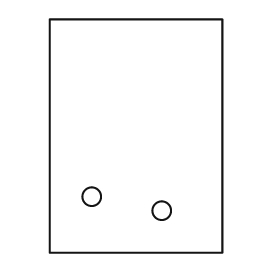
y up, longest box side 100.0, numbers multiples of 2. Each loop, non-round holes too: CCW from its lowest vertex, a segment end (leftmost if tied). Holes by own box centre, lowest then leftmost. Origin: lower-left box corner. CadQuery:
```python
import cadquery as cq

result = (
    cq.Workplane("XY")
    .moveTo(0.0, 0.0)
    .lineTo(74.0, 0.0)
    .lineTo(74.0, 100.0)
    .lineTo(0.0, 100.0)
    .close()
    .moveTo(48.0, 18.0)
    .circle(4.0)
    .moveTo(18.0, 24.0)
    .circle(4.0)
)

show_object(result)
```